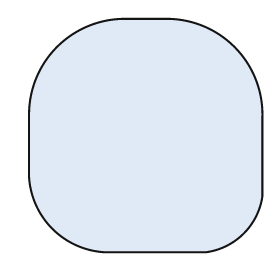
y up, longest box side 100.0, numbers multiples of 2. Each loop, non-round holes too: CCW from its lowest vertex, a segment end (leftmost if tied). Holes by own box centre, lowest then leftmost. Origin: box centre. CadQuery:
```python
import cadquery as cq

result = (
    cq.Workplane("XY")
    .moveTo(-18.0, -50.0)
    .lineTo(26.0, -50.0)
    .threePointArc((42.0, -42.0), (50.0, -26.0))
    .lineTo(50.0, 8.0)
    .threePointArc((38.0, 38.0), (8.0, 50.0))
    .lineTo(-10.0, 50.0)
    .threePointArc((-38.0, 38.0), (-50.0, 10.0))
    .lineTo(-50.0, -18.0)
    .threePointArc((-40.0, -40.0), (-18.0, -50.0))
    .close()
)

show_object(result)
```